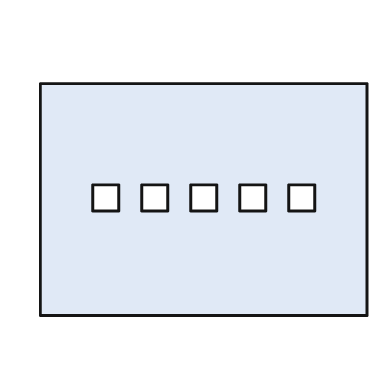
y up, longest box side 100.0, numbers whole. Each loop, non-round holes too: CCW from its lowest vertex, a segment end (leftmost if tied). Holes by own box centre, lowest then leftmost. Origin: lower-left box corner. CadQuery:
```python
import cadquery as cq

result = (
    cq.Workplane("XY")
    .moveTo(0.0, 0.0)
    .lineTo(100.0, 0.0)
    .lineTo(100.0, 71.0)
    .lineTo(0.0, 71.0)
    .close()
    .moveTo(16.0, 32.0)
    .lineTo(24.0, 32.0)
    .lineTo(24.0, 40.0)
    .lineTo(16.0, 40.0)
    .close()
    .moveTo(31.0, 32.0)
    .lineTo(39.0, 32.0)
    .lineTo(39.0, 40.0)
    .lineTo(31.0, 40.0)
    .close()
    .moveTo(46.0, 32.0)
    .lineTo(54.0, 32.0)
    .lineTo(54.0, 40.0)
    .lineTo(46.0, 40.0)
    .close()
    .moveTo(61.0, 32.0)
    .lineTo(69.0, 32.0)
    .lineTo(69.0, 40.0)
    .lineTo(61.0, 40.0)
    .close()
    .moveTo(76.0, 32.0)
    .lineTo(84.0, 32.0)
    .lineTo(84.0, 40.0)
    .lineTo(76.0, 40.0)
    .close()
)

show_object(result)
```